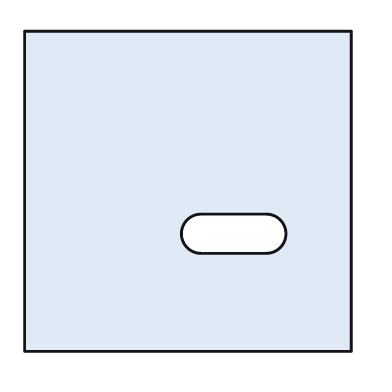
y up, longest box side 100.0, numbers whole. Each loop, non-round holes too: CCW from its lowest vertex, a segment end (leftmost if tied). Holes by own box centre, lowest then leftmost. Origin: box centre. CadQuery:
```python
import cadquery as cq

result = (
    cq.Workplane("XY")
    .moveTo(-50.0, -49.0)
    .lineTo(50.0, -49.0)
    .lineTo(50.0, 49.0)
    .lineTo(-50.0, 49.0)
    .close()
    .moveTo(4.0, -19.0)
    .lineTo(24.0, -19.0)
    .threePointArc((30.0, -13.0), (24.0, -7.0))
    .lineTo(4.0, -7.0)
    .threePointArc((-2.0, -13.0), (4.0, -19.0))
    .close()
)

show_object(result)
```